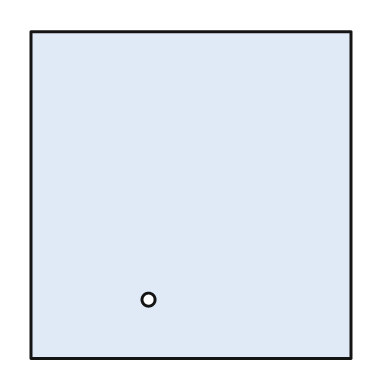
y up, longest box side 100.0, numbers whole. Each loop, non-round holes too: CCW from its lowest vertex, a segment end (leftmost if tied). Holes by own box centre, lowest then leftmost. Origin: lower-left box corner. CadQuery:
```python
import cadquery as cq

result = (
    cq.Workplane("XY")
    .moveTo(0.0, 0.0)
    .lineTo(98.0, 0.0)
    .lineTo(98.0, 100.0)
    .lineTo(0.0, 100.0)
    .close()
    .moveTo(36.0, 18.0)
    .circle(2.0)
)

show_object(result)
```